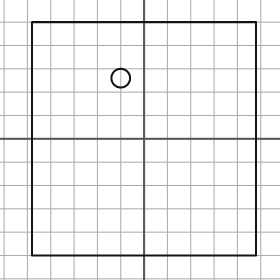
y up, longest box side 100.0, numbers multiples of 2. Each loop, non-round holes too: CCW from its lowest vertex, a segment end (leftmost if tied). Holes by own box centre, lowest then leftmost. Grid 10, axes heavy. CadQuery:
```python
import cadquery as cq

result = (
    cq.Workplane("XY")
    .moveTo(-48.0, -50.0)
    .lineTo(48.0, -50.0)
    .lineTo(48.0, 50.0)
    .lineTo(-48.0, 50.0)
    .close()
    .moveTo(-10.0, 26.0)
    .circle(4.0)
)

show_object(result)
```